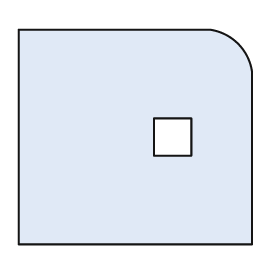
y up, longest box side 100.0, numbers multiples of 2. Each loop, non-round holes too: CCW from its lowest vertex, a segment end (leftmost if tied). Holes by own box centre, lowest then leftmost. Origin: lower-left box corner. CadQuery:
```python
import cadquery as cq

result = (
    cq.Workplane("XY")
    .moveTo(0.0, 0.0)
    .lineTo(100.0, 0.0)
    .lineTo(100.0, 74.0)
    .threePointArc((94.0, 86.0), (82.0, 92.0))
    .lineTo(0.0, 92.0)
    .close()
    .moveTo(58.0, 38.0)
    .lineTo(74.0, 38.0)
    .lineTo(74.0, 54.0)
    .lineTo(58.0, 54.0)
    .close()
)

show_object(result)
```